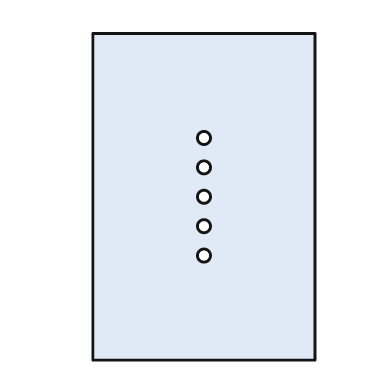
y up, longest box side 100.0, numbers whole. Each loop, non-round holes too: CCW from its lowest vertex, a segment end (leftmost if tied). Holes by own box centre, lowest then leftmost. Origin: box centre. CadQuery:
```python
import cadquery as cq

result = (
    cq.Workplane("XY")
    .moveTo(-34.0, -50.0)
    .lineTo(34.0, -50.0)
    .lineTo(34.0, 50.0)
    .lineTo(-34.0, 50.0)
    .close()
    .moveTo(0.0, -18.0)
    .circle(2.0)
    .moveTo(0.0, -9.0)
    .circle(2.0)
    .moveTo(0.0, 0.0)
    .circle(2.0)
    .moveTo(0.0, 9.0)
    .circle(2.0)
    .moveTo(0.0, 18.0)
    .circle(2.0)
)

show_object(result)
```